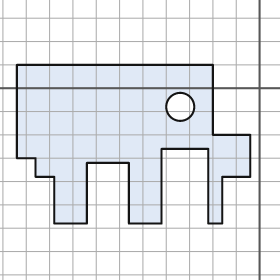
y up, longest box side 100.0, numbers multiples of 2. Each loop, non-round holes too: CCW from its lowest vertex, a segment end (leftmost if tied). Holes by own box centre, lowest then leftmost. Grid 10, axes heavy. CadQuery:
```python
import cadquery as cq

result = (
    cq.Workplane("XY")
    .moveTo(-88.0, -58.0)
    .lineTo(-74.0, -58.0)
    .lineTo(-74.0, -32.0)
    .lineTo(-56.0, -32.0)
    .lineTo(-56.0, -58.0)
    .lineTo(-42.0, -58.0)
    .lineTo(-42.0, -26.0)
    .lineTo(-22.0, -26.0)
    .lineTo(-22.0, -58.0)
    .lineTo(-16.0, -58.0)
    .lineTo(-16.0, -38.0)
    .lineTo(-4.0, -38.0)
    .lineTo(-4.0, -20.0)
    .lineTo(-20.0, -20.0)
    .lineTo(-20.0, 10.0)
    .lineTo(-104.0, 10.0)
    .lineTo(-104.0, -30.0)
    .lineTo(-96.0, -30.0)
    .lineTo(-96.0, -38.0)
    .lineTo(-88.0, -38.0)
    .close()
    .moveTo(-34.0, -8.0)
    .circle(6.0)
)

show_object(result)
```